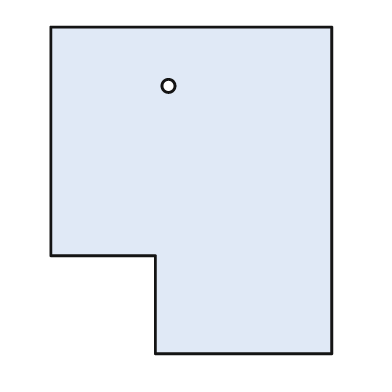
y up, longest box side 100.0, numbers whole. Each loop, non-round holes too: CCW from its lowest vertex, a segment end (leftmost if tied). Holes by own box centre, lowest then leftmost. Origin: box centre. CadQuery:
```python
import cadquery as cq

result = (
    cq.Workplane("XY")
    .moveTo(-11.0, -50.0)
    .lineTo(43.0, -50.0)
    .lineTo(43.0, 50.0)
    .lineTo(-43.0, 50.0)
    .lineTo(-43.0, -20.0)
    .lineTo(-11.0, -20.0)
    .close()
    .moveTo(-7.0, 32.0)
    .circle(2.0)
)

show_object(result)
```